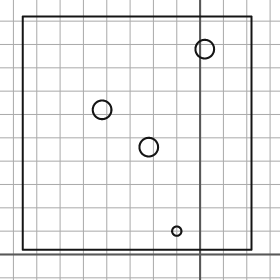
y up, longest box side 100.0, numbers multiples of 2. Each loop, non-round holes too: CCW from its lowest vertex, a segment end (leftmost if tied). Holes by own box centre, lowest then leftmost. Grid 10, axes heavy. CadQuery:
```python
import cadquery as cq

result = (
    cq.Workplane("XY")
    .moveTo(-76.0, 2.0)
    .lineTo(22.0, 2.0)
    .lineTo(22.0, 102.0)
    .lineTo(-76.0, 102.0)
    .close()
    .moveTo(-10.0, 10.0)
    .circle(2.0)
    .moveTo(-22.0, 46.0)
    .circle(4.0)
    .moveTo(-42.0, 62.0)
    .circle(4.0)
    .moveTo(2.0, 88.0)
    .circle(4.0)
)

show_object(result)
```